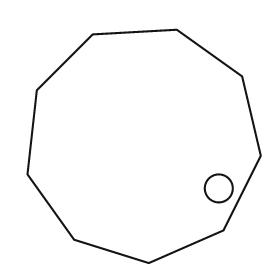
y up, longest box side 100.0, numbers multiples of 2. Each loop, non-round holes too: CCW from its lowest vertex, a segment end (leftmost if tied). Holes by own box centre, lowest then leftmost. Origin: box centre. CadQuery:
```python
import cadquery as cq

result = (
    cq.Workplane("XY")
    .moveTo(2.0, -50.0)
    .lineTo(34.0, -36.0)
    .lineTo(50.0, -4.0)
    .lineTo(42.0, 30.0)
    .lineTo(14.0, 50.0)
    .lineTo(-22.0, 48.0)
    .lineTo(-46.0, 24.0)
    .lineTo(-50.0, -12.0)
    .lineTo(-30.0, -40.0)
    .close()
    .moveTo(32.0, -18.0)
    .circle(6.0)
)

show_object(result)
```